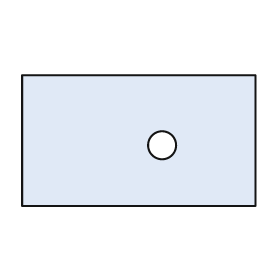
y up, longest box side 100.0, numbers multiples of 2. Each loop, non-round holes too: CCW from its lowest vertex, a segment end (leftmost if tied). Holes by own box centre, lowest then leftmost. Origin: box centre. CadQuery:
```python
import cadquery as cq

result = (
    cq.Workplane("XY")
    .moveTo(-50.0, -28.0)
    .lineTo(50.0, -28.0)
    .lineTo(50.0, 28.0)
    .lineTo(-50.0, 28.0)
    .close()
    .moveTo(10.0, -2.0)
    .circle(6.0)
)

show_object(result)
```